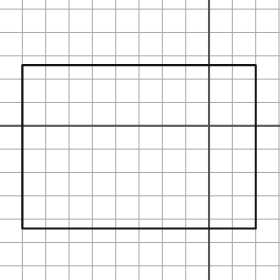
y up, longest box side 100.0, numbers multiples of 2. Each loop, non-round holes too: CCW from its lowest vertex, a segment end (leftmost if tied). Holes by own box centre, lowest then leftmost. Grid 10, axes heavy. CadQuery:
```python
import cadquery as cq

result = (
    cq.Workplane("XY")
    .moveTo(-80.0, -44.0)
    .lineTo(20.0, -44.0)
    .lineTo(20.0, 26.0)
    .lineTo(-80.0, 26.0)
    .close()
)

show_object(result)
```